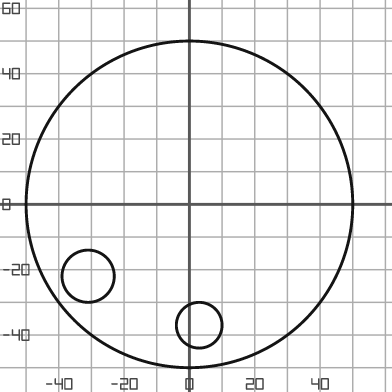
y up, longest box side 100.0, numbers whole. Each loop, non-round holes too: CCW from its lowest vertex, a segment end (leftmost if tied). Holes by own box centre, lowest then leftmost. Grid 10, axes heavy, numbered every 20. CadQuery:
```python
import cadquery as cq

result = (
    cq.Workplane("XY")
    .moveTo(0.0, 0.0)
    .circle(50.0)
    .moveTo(3.0, -37.0)
    .circle(7.0)
    .moveTo(-31.0, -22.0)
    .circle(8.0)
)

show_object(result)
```